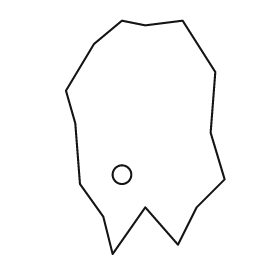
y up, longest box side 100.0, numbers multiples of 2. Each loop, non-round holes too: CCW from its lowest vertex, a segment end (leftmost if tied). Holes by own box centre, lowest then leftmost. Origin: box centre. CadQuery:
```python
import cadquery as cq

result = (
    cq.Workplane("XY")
    .moveTo(-14.0, -50.0)
    .lineTo(0.0, -30.0)
    .lineTo(14.0, -46.0)
    .lineTo(22.0, -30.0)
    .lineTo(34.0, -18.0)
    .lineTo(28.0, 2.0)
    .lineTo(30.0, 28.0)
    .lineTo(16.0, 50.0)
    .lineTo(0.0, 48.0)
    .lineTo(-10.0, 50.0)
    .lineTo(-22.0, 40.0)
    .lineTo(-34.0, 20.0)
    .lineTo(-30.0, 6.0)
    .lineTo(-28.0, -20.0)
    .lineTo(-18.0, -34.0)
    .close()
    .moveTo(-10.0, -16.0)
    .circle(4.0)
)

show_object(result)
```